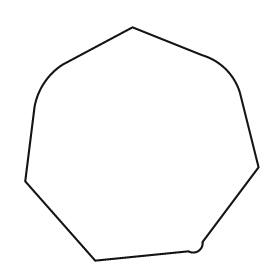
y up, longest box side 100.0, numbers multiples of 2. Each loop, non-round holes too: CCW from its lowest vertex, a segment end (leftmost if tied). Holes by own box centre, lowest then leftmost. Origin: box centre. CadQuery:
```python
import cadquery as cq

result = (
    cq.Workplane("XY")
    .moveTo(-20.0, -50.0)
    .lineTo(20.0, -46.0)
    .threePointArc((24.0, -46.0), (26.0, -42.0))
    .lineTo(50.0, -10.0)
    .lineTo(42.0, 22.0)
    .threePointArc((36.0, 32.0), (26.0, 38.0))
    .lineTo(-4.0, 50.0)
    .lineTo(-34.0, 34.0)
    .threePointArc((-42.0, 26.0), (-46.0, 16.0))
    .lineTo(-50.0, -16.0)
    .close()
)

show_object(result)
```